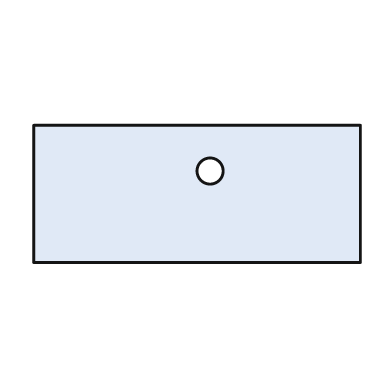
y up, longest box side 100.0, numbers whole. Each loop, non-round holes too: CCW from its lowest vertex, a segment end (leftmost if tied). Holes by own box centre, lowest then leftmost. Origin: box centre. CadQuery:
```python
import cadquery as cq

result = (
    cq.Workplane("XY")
    .moveTo(-50.0, -21.0)
    .lineTo(50.0, -21.0)
    .lineTo(50.0, 21.0)
    .lineTo(-50.0, 21.0)
    .close()
    .moveTo(4.0, 7.0)
    .circle(4.0)
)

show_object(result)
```